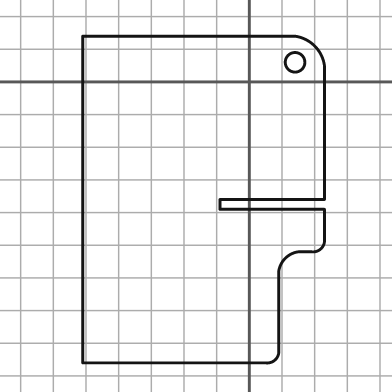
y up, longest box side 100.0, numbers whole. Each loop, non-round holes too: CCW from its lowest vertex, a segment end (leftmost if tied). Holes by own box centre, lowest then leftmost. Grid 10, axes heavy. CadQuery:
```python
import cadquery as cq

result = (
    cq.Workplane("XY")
    .moveTo(-51.0, -86.0)
    .lineTo(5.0, -86.0)
    .threePointArc((8.0, -85.0), (9.0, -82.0))
    .lineTo(9.0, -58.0)
    .threePointArc((11.0, -54.0), (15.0, -52.0))
    .lineTo(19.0, -52.0)
    .threePointArc((22.0, -51.0), (23.0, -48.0))
    .lineTo(23.0, -39.0)
    .lineTo(-9.0, -39.0)
    .lineTo(-9.0, -36.0)
    .lineTo(23.0, -36.0)
    .lineTo(23.0, 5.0)
    .threePointArc((20.0, 11.0), (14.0, 14.0))
    .lineTo(-51.0, 14.0)
    .close()
    .moveTo(14.0, 6.0)
    .circle(3.0)
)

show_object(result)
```